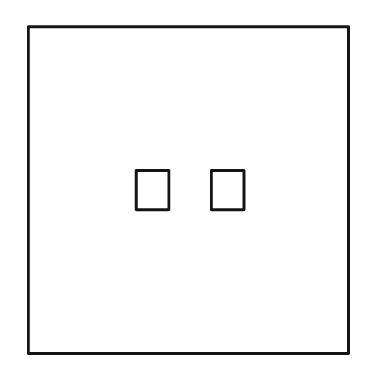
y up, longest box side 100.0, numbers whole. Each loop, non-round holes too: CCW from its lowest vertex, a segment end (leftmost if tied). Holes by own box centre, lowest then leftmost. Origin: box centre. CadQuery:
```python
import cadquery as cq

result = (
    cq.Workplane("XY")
    .moveTo(-49.0, -50.0)
    .lineTo(49.0, -50.0)
    .lineTo(49.0, 50.0)
    .lineTo(-49.0, 50.0)
    .close()
    .moveTo(-16.0, -6.0)
    .lineTo(-6.0, -6.0)
    .lineTo(-6.0, 6.0)
    .lineTo(-16.0, 6.0)
    .close()
    .moveTo(7.0, -6.0)
    .lineTo(17.0, -6.0)
    .lineTo(17.0, 6.0)
    .lineTo(7.0, 6.0)
    .close()
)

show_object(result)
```